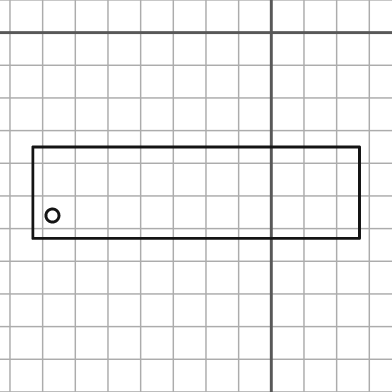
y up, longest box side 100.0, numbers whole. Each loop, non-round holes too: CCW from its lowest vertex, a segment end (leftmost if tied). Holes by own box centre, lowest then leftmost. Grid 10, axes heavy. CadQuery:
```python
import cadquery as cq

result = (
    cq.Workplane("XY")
    .moveTo(-73.0, -63.0)
    .lineTo(27.0, -63.0)
    .lineTo(27.0, -35.0)
    .lineTo(-73.0, -35.0)
    .close()
    .moveTo(-67.0, -56.0)
    .circle(2.0)
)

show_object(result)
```